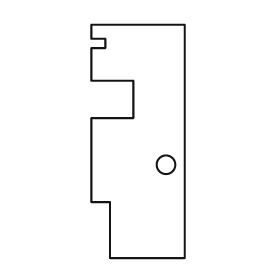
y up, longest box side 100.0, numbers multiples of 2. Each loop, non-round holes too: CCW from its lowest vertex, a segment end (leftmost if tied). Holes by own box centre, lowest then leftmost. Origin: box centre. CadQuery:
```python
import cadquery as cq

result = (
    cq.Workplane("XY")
    .moveTo(-12.0, -50.0)
    .lineTo(20.0, -50.0)
    .lineTo(20.0, 50.0)
    .lineTo(-20.0, 50.0)
    .lineTo(-20.0, 44.0)
    .lineTo(-14.0, 44.0)
    .lineTo(-14.0, 40.0)
    .lineTo(-20.0, 40.0)
    .lineTo(-20.0, 26.0)
    .lineTo(-2.0, 26.0)
    .lineTo(-2.0, 10.0)
    .lineTo(-20.0, 10.0)
    .lineTo(-20.0, -26.0)
    .lineTo(-12.0, -26.0)
    .close()
    .moveTo(12.0, -10.0)
    .circle(4.0)
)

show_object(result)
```